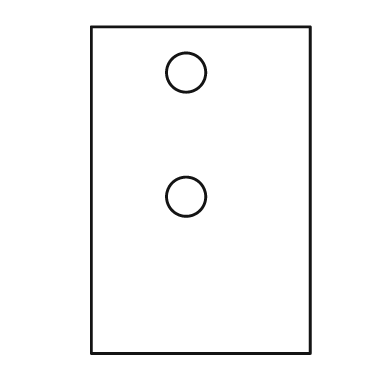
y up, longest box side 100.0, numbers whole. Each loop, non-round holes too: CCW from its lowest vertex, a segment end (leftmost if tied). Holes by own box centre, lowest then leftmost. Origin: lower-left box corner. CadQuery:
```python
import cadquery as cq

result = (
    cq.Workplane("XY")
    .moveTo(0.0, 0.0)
    .lineTo(67.0, 0.0)
    .lineTo(67.0, 100.0)
    .lineTo(0.0, 100.0)
    .close()
    .moveTo(29.0, 48.0)
    .circle(6.0)
    .moveTo(29.0, 86.0)
    .circle(6.0)
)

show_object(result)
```